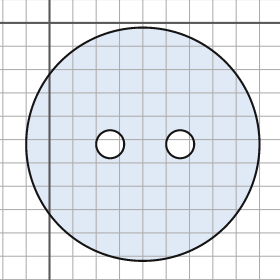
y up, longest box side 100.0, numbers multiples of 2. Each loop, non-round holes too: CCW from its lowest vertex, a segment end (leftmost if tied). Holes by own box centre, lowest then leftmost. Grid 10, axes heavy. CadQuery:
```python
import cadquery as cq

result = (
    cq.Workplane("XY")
    .moveTo(40.0, -52.0)
    .circle(50.0)
    .moveTo(26.0, -52.0)
    .circle(6.0)
    .moveTo(56.0, -52.0)
    .circle(6.0)
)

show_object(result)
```